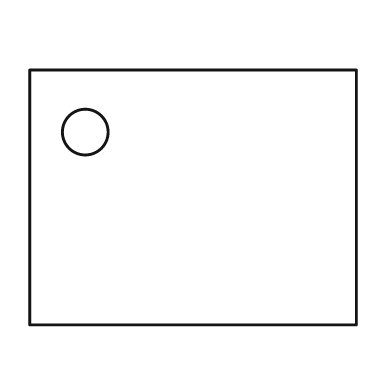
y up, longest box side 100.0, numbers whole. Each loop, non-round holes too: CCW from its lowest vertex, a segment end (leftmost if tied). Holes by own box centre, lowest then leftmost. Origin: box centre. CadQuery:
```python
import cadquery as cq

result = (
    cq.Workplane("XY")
    .moveTo(-50.0, -39.0)
    .lineTo(50.0, -39.0)
    .lineTo(50.0, 39.0)
    .lineTo(-50.0, 39.0)
    .close()
    .moveTo(-33.0, 20.0)
    .circle(7.0)
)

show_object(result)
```